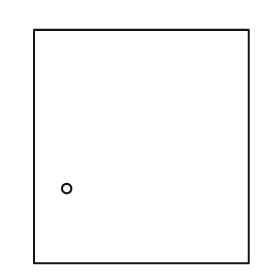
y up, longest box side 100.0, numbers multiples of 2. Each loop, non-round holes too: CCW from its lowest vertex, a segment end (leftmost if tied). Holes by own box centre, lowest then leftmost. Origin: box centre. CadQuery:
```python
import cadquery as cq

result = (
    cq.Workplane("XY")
    .moveTo(-46.0, -50.0)
    .lineTo(46.0, -50.0)
    .lineTo(46.0, 50.0)
    .lineTo(-46.0, 50.0)
    .close()
    .moveTo(-32.0, -18.0)
    .circle(2.0)
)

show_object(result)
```